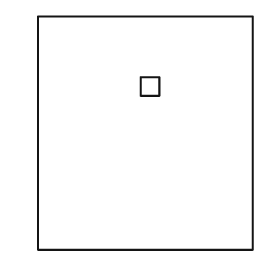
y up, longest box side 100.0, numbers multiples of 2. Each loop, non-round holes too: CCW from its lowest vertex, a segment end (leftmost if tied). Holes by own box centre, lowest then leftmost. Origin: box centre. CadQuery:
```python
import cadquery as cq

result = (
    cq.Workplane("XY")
    .moveTo(-46.0, -50.0)
    .lineTo(46.0, -50.0)
    .lineTo(46.0, 50.0)
    .lineTo(-46.0, 50.0)
    .close()
    .moveTo(-2.0, 16.0)
    .lineTo(6.0, 16.0)
    .lineTo(6.0, 24.0)
    .lineTo(-2.0, 24.0)
    .close()
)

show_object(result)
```